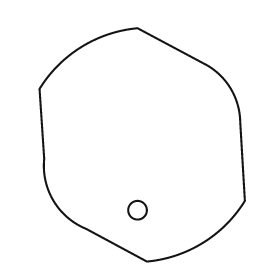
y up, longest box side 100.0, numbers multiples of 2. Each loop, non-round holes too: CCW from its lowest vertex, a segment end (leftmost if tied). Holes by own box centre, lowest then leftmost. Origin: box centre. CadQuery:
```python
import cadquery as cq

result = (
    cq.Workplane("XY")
    .moveTo(2.0, -50.0)
    .threePointArc((26.0, -42.0), (44.0, -24.0))
    .lineTo(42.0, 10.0)
    .threePointArc((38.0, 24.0), (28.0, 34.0))
    .lineTo(-2.0, 50.0)
    .threePointArc((-26.0, 42.0), (-44.0, 24.0))
    .lineTo(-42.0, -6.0)
    .threePointArc((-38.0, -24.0), (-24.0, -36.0))
    .close()
    .moveTo(-2.0, -28.0)
    .circle(4.0)
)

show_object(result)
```